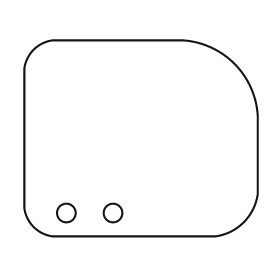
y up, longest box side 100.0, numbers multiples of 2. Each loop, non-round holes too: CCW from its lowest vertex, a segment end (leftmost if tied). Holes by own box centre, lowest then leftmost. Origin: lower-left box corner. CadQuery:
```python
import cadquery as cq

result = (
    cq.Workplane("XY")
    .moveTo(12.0, 0.0)
    .lineTo(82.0, 0.0)
    .threePointArc((94.0, 6.0), (100.0, 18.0))
    .lineTo(100.0, 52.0)
    .threePointArc((90.0, 74.0), (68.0, 84.0))
    .lineTo(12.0, 84.0)
    .threePointArc((4.0, 80.0), (0.0, 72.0))
    .lineTo(0.0, 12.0)
    .threePointArc((4.0, 4.0), (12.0, 0.0))
    .close()
    .moveTo(18.0, 10.0)
    .circle(4.0)
    .moveTo(38.0, 10.0)
    .circle(4.0)
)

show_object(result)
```